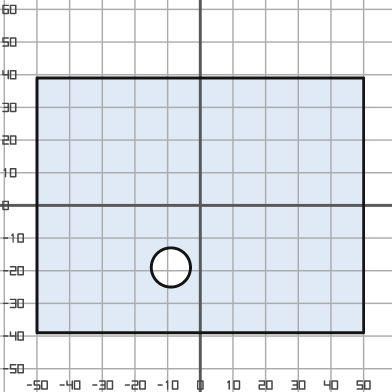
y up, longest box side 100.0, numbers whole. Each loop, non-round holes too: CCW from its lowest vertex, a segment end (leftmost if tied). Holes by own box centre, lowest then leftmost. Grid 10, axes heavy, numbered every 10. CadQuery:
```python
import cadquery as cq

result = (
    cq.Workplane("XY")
    .moveTo(-50.0, -39.0)
    .lineTo(50.0, -39.0)
    .lineTo(50.0, 39.0)
    .lineTo(-50.0, 39.0)
    .close()
    .moveTo(-9.0, -19.0)
    .circle(6.0)
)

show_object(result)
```